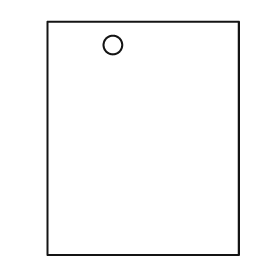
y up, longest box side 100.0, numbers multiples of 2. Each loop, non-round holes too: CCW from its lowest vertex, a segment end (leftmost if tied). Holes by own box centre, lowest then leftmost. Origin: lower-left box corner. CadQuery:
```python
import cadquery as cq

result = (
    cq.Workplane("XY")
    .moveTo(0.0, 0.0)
    .lineTo(82.0, 0.0)
    .lineTo(82.0, 100.0)
    .lineTo(0.0, 100.0)
    .close()
    .moveTo(28.0, 90.0)
    .circle(4.0)
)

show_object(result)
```